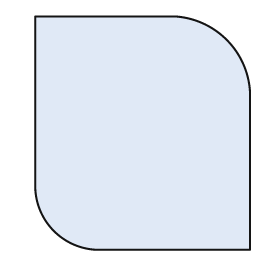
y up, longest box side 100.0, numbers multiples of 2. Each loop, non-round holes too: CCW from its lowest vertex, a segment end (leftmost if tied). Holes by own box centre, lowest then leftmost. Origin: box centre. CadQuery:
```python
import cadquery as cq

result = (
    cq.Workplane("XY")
    .moveTo(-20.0, -50.0)
    .lineTo(46.0, -50.0)
    .lineTo(46.0, 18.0)
    .threePointArc((36.0, 40.0), (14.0, 50.0))
    .lineTo(-46.0, 50.0)
    .lineTo(-46.0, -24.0)
    .threePointArc((-38.0, -42.0), (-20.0, -50.0))
    .close()
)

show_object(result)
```